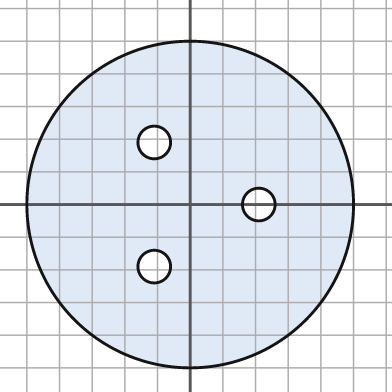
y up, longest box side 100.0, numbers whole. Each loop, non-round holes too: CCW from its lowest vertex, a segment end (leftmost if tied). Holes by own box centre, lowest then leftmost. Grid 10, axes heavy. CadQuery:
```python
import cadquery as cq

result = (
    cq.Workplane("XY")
    .moveTo(0.0, 0.0)
    .circle(50.0)
    .moveTo(-11.0, -19.0)
    .circle(5.0)
    .moveTo(21.0, 0.0)
    .circle(5.0)
    .moveTo(-11.0, 19.0)
    .circle(5.0)
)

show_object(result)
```